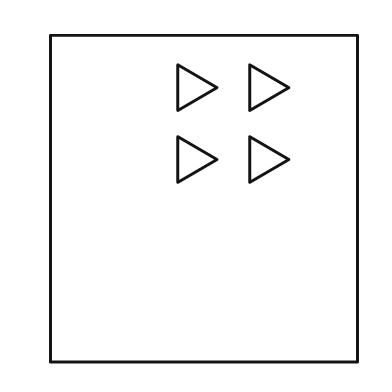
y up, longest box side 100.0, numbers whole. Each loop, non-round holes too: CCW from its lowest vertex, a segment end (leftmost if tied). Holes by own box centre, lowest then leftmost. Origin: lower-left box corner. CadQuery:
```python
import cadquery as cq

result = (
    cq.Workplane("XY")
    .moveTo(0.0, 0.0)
    .lineTo(94.0, 0.0)
    .lineTo(94.0, 100.0)
    .lineTo(0.0, 100.0)
    .close()
    .moveTo(39.0, 55.0)
    .lineTo(51.0, 62.0)
    .lineTo(39.0, 69.0)
    .close()
    .moveTo(61.0, 55.0)
    .lineTo(73.0, 62.0)
    .lineTo(61.0, 69.0)
    .close()
    .moveTo(39.0, 77.0)
    .lineTo(51.0, 84.0)
    .lineTo(39.0, 91.0)
    .close()
    .moveTo(61.0, 77.0)
    .lineTo(73.0, 84.0)
    .lineTo(61.0, 91.0)
    .close()
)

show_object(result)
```